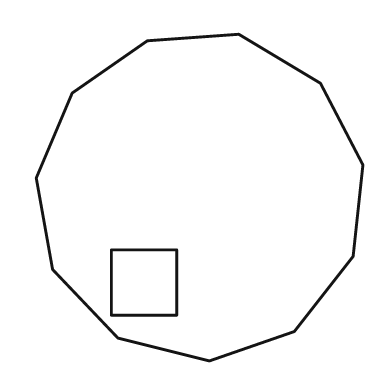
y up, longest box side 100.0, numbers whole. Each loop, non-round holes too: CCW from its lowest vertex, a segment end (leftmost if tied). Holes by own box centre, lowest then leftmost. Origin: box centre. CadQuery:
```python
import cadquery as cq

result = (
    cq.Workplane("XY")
    .moveTo(3.0, -50.0)
    .lineTo(29.0, -41.0)
    .lineTo(47.0, -18.0)
    .lineTo(50.0, 10.0)
    .lineTo(37.0, 35.0)
    .lineTo(12.0, 50.0)
    .lineTo(-16.0, 48.0)
    .lineTo(-39.0, 32.0)
    .lineTo(-50.0, 6.0)
    .lineTo(-45.0, -22.0)
    .lineTo(-25.0, -43.0)
    .close()
    .moveTo(-27.0, -36.0)
    .lineTo(-7.0, -36.0)
    .lineTo(-7.0, -16.0)
    .lineTo(-27.0, -16.0)
    .close()
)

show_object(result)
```